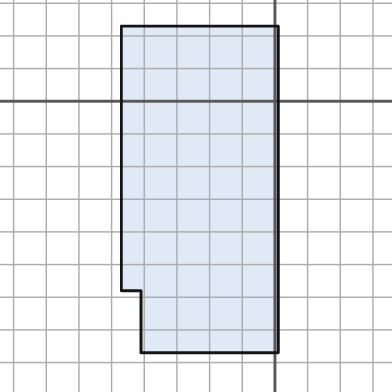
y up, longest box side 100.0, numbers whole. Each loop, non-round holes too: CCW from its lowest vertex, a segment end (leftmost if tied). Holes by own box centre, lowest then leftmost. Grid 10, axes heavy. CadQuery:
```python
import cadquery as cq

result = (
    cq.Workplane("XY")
    .moveTo(-41.0, -77.0)
    .lineTo(1.0, -77.0)
    .lineTo(1.0, 23.0)
    .lineTo(-47.0, 23.0)
    .lineTo(-47.0, -58.0)
    .lineTo(-41.0, -58.0)
    .close()
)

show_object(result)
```